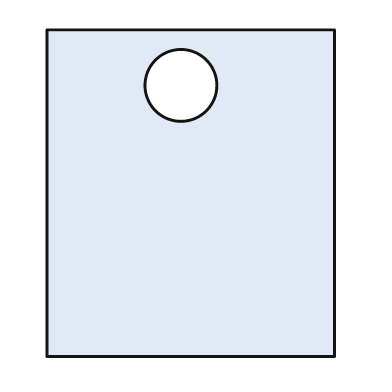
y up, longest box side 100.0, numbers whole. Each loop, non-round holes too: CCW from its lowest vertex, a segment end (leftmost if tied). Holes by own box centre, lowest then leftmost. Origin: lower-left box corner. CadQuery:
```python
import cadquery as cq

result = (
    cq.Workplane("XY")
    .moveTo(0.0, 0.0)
    .lineTo(88.0, 0.0)
    .lineTo(88.0, 100.0)
    .lineTo(0.0, 100.0)
    .close()
    .moveTo(41.0, 83.0)
    .circle(11.0)
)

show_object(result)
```